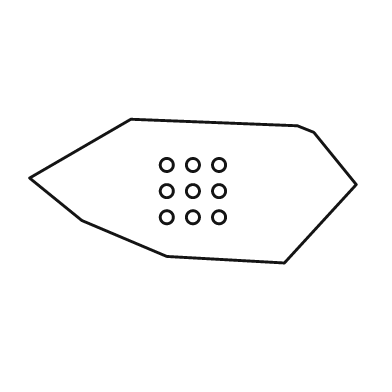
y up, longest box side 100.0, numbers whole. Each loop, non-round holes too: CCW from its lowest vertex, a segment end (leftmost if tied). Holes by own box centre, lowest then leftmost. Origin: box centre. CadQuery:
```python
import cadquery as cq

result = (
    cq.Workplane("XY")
    .moveTo(28.0, -22.0)
    .lineTo(50.0, 2.0)
    .lineTo(37.0, 18.0)
    .lineTo(32.0, 20.0)
    .lineTo(-19.0, 22.0)
    .lineTo(-50.0, 4.0)
    .lineTo(-34.0, -9.0)
    .lineTo(-8.0, -20.0)
    .close()
    .moveTo(-8.0, -8.0)
    .circle(2.0)
    .moveTo(0.0, -8.0)
    .circle(2.0)
    .moveTo(8.0, -8.0)
    .circle(2.0)
    .moveTo(-8.0, 0.0)
    .circle(2.0)
    .moveTo(0.0, 0.0)
    .circle(2.0)
    .moveTo(8.0, 0.0)
    .circle(2.0)
    .moveTo(-8.0, 8.0)
    .circle(2.0)
    .moveTo(0.0, 8.0)
    .circle(2.0)
    .moveTo(8.0, 8.0)
    .circle(2.0)
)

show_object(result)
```